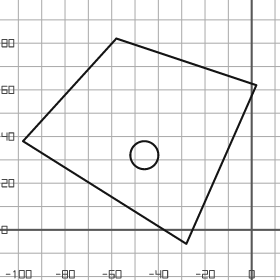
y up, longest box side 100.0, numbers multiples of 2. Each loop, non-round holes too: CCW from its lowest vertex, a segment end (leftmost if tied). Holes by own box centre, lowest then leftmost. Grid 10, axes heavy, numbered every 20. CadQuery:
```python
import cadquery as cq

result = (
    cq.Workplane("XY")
    .moveTo(-28.0, -6.0)
    .lineTo(2.0, 62.0)
    .lineTo(-58.0, 82.0)
    .lineTo(-98.0, 38.0)
    .close()
    .moveTo(-46.0, 32.0)
    .circle(6.0)
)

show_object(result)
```